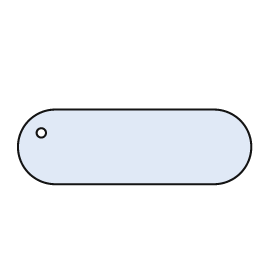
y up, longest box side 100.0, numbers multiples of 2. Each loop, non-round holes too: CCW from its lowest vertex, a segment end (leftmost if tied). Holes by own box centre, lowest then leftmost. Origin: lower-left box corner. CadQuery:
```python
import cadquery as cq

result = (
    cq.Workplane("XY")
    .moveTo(16.0, 0.0)
    .lineTo(84.0, 0.0)
    .threePointArc((100.0, 16.0), (84.0, 32.0))
    .lineTo(16.0, 32.0)
    .threePointArc((0.0, 16.0), (16.0, 0.0))
    .close()
    .moveTo(10.0, 22.0)
    .circle(2.0)
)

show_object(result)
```